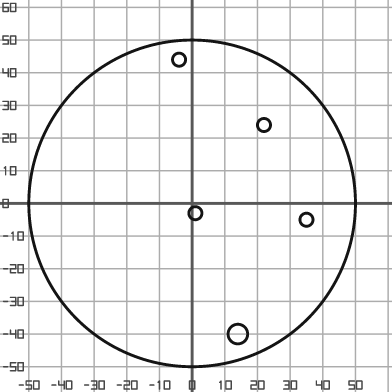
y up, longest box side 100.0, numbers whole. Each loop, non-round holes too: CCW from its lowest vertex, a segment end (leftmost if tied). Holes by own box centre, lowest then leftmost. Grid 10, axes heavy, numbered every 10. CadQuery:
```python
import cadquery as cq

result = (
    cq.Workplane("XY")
    .moveTo(0.0, 0.0)
    .circle(50.0)
    .moveTo(14.0, -40.0)
    .circle(3.0)
    .moveTo(35.0, -5.0)
    .circle(2.0)
    .moveTo(1.0, -3.0)
    .circle(2.0)
    .moveTo(22.0, 24.0)
    .circle(2.0)
    .moveTo(-4.0, 44.0)
    .circle(2.0)
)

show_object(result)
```